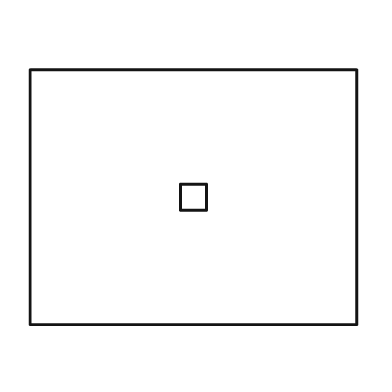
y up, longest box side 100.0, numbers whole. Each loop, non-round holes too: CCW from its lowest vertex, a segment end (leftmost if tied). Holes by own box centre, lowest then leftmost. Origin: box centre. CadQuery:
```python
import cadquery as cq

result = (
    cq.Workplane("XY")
    .moveTo(-50.0, -39.0)
    .lineTo(50.0, -39.0)
    .lineTo(50.0, 39.0)
    .lineTo(-50.0, 39.0)
    .close()
    .moveTo(-4.0, -4.0)
    .lineTo(4.0, -4.0)
    .lineTo(4.0, 4.0)
    .lineTo(-4.0, 4.0)
    .close()
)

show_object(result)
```